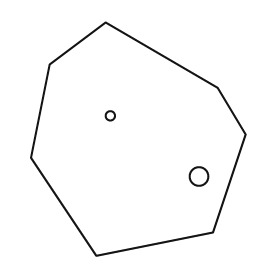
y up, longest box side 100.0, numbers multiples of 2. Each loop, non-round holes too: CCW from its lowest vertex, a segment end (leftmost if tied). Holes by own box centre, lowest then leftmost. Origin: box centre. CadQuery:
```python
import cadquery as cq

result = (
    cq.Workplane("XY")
    .moveTo(-18.0, -50.0)
    .lineTo(32.0, -40.0)
    .lineTo(46.0, 2.0)
    .lineTo(34.0, 22.0)
    .lineTo(-14.0, 50.0)
    .lineTo(-38.0, 32.0)
    .lineTo(-46.0, -8.0)
    .close()
    .moveTo(26.0, -16.0)
    .circle(4.0)
    .moveTo(-12.0, 10.0)
    .circle(2.0)
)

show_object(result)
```